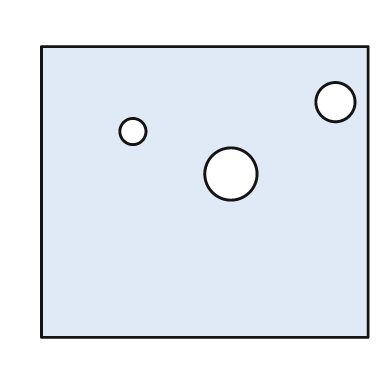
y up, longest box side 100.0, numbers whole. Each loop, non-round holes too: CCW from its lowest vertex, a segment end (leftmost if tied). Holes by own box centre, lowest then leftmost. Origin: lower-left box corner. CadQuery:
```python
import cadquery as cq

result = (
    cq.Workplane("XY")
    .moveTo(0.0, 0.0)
    .lineTo(100.0, 0.0)
    .lineTo(100.0, 89.0)
    .lineTo(0.0, 89.0)
    .close()
    .moveTo(58.0, 50.0)
    .circle(8.0)
    .moveTo(28.0, 63.0)
    .circle(4.0)
    .moveTo(90.0, 72.0)
    .circle(6.0)
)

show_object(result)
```